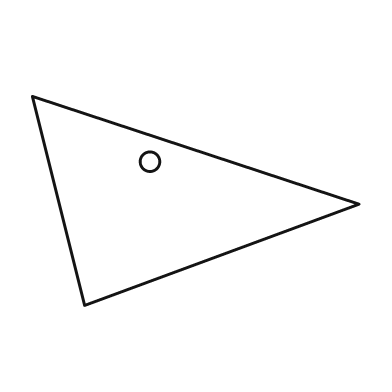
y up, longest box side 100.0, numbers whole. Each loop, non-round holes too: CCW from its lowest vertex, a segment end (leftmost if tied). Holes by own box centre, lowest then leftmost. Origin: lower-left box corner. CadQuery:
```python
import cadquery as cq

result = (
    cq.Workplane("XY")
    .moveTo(16.0, 0.0)
    .lineTo(100.0, 31.0)
    .lineTo(0.0, 64.0)
    .close()
    .moveTo(36.0, 44.0)
    .circle(3.0)
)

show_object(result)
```